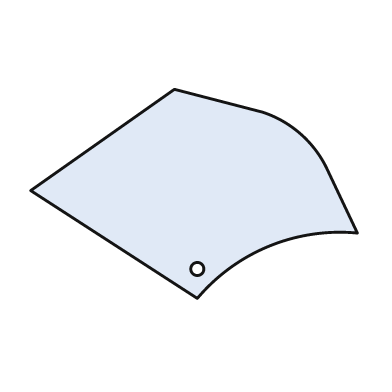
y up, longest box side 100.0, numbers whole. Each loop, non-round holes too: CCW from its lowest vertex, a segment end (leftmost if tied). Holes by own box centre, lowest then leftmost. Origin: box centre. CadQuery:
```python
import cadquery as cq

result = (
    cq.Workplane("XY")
    .moveTo(1.0, -32.0)
    .threePointArc((23.0, -16.0), (50.0, -12.0))
    .lineTo(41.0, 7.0)
    .threePointArc((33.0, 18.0), (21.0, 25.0))
    .lineTo(-6.0, 32.0)
    .lineTo(-50.0, 1.0)
    .close()
    .moveTo(1.0, -23.0)
    .circle(2.0)
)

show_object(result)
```